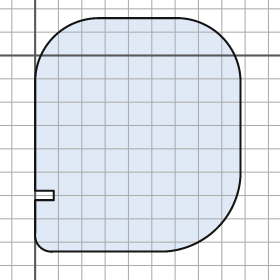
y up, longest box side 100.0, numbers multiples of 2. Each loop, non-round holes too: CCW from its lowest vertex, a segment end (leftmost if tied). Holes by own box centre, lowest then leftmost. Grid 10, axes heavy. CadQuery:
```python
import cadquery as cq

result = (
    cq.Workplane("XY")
    .moveTo(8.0, -84.0)
    .lineTo(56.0, -84.0)
    .threePointArc((78.0, -74.0), (88.0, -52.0))
    .lineTo(88.0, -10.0)
    .threePointArc((80.0, 8.0), (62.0, 16.0))
    .lineTo(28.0, 16.0)
    .threePointArc((8.0, 8.0), (0.0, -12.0))
    .lineTo(0.0, -58.0)
    .lineTo(8.0, -58.0)
    .lineTo(8.0, -62.0)
    .lineTo(0.0, -62.0)
    .lineTo(0.0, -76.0)
    .threePointArc((2.0, -82.0), (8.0, -84.0))
    .close()
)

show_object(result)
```